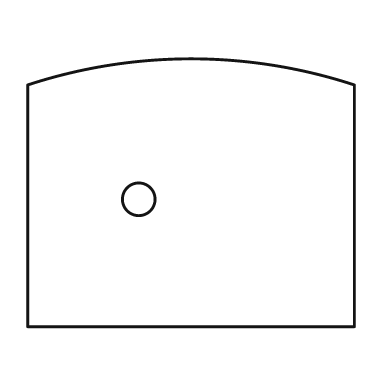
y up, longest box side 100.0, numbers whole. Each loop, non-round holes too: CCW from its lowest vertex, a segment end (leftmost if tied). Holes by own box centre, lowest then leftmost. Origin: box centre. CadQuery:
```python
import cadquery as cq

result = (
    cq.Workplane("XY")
    .moveTo(-50.0, -41.0)
    .lineTo(50.0, -41.0)
    .lineTo(50.0, 33.0)
    .threePointArc((0.0, 41.0), (-50.0, 33.0))
    .close()
    .moveTo(-16.0, -2.0)
    .circle(5.0)
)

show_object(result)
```